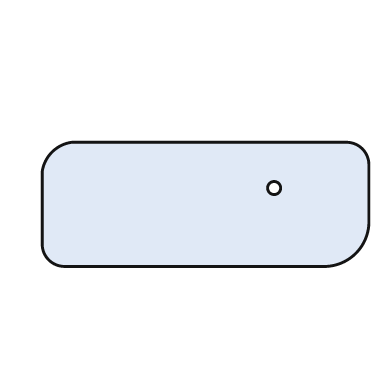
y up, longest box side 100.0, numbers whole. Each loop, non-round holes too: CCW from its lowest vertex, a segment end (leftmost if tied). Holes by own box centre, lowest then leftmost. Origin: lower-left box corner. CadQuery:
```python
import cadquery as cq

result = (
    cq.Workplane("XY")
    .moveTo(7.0, 0.0)
    .lineTo(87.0, 0.0)
    .threePointArc((96.0, 4.0), (100.0, 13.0))
    .lineTo(100.0, 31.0)
    .threePointArc((98.0, 36.0), (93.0, 38.0))
    .lineTo(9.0, 38.0)
    .threePointArc((3.0, 35.0), (0.0, 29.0))
    .lineTo(0.0, 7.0)
    .threePointArc((2.0, 2.0), (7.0, 0.0))
    .close()
    .moveTo(71.0, 24.0)
    .circle(2.0)
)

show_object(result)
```